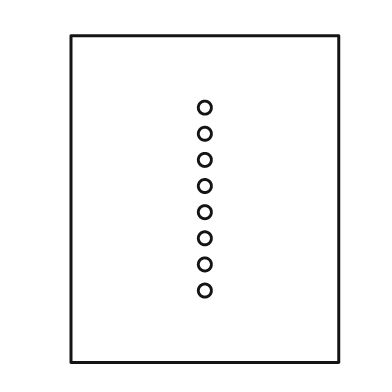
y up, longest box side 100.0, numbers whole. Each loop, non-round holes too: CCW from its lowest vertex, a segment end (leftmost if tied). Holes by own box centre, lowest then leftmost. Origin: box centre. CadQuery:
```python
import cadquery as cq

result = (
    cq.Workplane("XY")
    .moveTo(-41.0, -50.0)
    .lineTo(41.0, -50.0)
    .lineTo(41.0, 50.0)
    .lineTo(-41.0, 50.0)
    .close()
    .moveTo(0.0, -28.0)
    .circle(2.0)
    .moveTo(0.0, -20.0)
    .circle(2.0)
    .moveTo(0.0, -12.0)
    .circle(2.0)
    .moveTo(0.0, -4.0)
    .circle(2.0)
    .moveTo(0.0, 4.0)
    .circle(2.0)
    .moveTo(0.0, 12.0)
    .circle(2.0)
    .moveTo(0.0, 20.0)
    .circle(2.0)
    .moveTo(0.0, 28.0)
    .circle(2.0)
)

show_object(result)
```